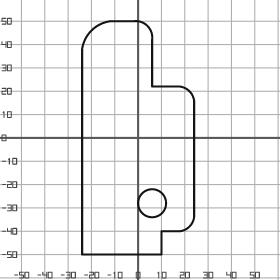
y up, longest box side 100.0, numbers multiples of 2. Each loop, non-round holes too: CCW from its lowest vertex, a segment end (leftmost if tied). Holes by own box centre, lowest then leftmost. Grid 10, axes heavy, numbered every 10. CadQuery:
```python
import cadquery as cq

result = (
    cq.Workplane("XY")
    .moveTo(-24.0, -50.0)
    .lineTo(10.0, -50.0)
    .lineTo(10.0, -40.0)
    .lineTo(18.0, -40.0)
    .threePointArc((22.0, -38.0), (24.0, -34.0))
    .lineTo(24.0, 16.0)
    .threePointArc((22.0, 20.0), (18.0, 22.0))
    .lineTo(6.0, 22.0)
    .lineTo(6.0, 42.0)
    .threePointArc((4.0, 48.0), (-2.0, 50.0))
    .lineTo(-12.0, 50.0)
    .threePointArc((-20.0, 46.0), (-24.0, 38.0))
    .close()
    .moveTo(6.0, -28.0)
    .circle(6.0)
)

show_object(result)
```